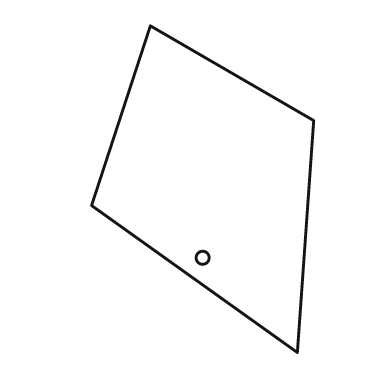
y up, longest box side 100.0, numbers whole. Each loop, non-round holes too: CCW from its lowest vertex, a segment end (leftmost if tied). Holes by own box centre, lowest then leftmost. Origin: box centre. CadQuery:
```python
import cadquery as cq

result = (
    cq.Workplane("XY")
    .moveTo(29.0, -50.0)
    .lineTo(34.0, 21.0)
    .lineTo(-16.0, 50.0)
    .lineTo(-34.0, -5.0)
    .close()
    .moveTo(0.0, -21.0)
    .circle(2.0)
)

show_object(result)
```